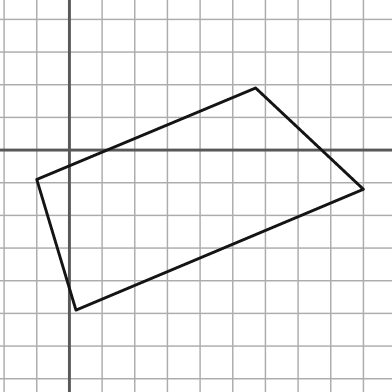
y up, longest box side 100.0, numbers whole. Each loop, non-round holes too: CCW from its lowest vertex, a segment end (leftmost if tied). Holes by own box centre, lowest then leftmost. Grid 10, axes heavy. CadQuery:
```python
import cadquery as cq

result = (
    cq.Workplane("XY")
    .moveTo(2.0, -49.0)
    .lineTo(90.0, -12.0)
    .lineTo(57.0, 19.0)
    .lineTo(-10.0, -9.0)
    .close()
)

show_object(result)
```